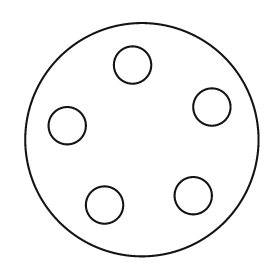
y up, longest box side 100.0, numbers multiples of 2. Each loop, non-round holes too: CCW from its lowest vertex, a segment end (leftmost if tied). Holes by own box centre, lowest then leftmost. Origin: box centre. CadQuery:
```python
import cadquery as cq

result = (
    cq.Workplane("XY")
    .moveTo(0.0, 0.0)
    .circle(50.0)
    .moveTo(-16.0, -28.0)
    .circle(8.0)
    .moveTo(22.0, -24.0)
    .circle(8.0)
    .moveTo(-32.0, 6.0)
    .circle(8.0)
    .moveTo(30.0, 14.0)
    .circle(8.0)
    .moveTo(-4.0, 32.0)
    .circle(8.0)
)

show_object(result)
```